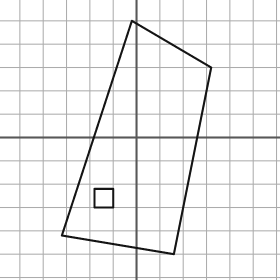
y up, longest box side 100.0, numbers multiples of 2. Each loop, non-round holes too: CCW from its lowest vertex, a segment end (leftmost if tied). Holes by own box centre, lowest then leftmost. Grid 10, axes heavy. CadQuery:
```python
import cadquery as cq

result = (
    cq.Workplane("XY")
    .moveTo(16.0, -50.0)
    .lineTo(32.0, 30.0)
    .lineTo(-2.0, 50.0)
    .lineTo(-32.0, -42.0)
    .close()
    .moveTo(-18.0, -30.0)
    .lineTo(-10.0, -30.0)
    .lineTo(-10.0, -22.0)
    .lineTo(-18.0, -22.0)
    .close()
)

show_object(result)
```